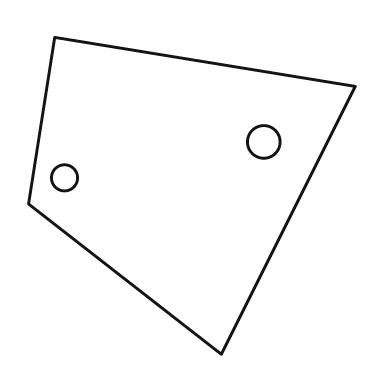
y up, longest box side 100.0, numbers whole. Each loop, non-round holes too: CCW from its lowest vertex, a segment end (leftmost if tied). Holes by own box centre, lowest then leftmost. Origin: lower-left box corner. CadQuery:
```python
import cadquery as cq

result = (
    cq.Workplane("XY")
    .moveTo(59.0, 0.0)
    .lineTo(100.0, 82.0)
    .lineTo(8.0, 97.0)
    .lineTo(0.0, 46.0)
    .close()
    .moveTo(11.0, 54.0)
    .circle(4.0)
    .moveTo(72.0, 65.0)
    .circle(5.0)
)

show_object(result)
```